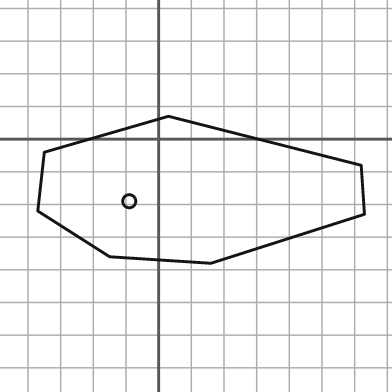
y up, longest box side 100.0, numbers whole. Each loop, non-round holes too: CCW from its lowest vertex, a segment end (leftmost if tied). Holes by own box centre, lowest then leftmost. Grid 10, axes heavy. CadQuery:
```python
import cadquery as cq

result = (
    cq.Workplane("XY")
    .moveTo(16.0, -38.0)
    .lineTo(63.0, -23.0)
    .lineTo(62.0, -8.0)
    .lineTo(3.0, 7.0)
    .lineTo(-35.0, -4.0)
    .lineTo(-37.0, -22.0)
    .lineTo(-15.0, -36.0)
    .close()
    .moveTo(-9.0, -19.0)
    .circle(2.0)
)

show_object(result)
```